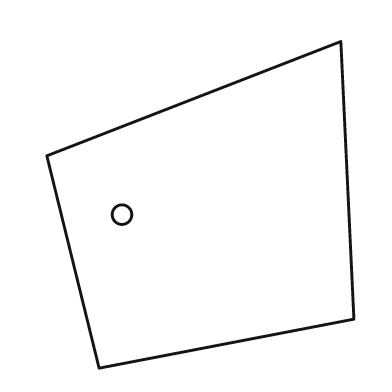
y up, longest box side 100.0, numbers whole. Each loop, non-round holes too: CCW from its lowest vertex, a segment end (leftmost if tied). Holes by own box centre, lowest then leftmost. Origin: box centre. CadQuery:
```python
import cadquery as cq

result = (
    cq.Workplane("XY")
    .moveTo(-31.0, -50.0)
    .lineTo(47.0, -35.0)
    .lineTo(43.0, 50.0)
    .lineTo(-47.0, 15.0)
    .close()
    .moveTo(-24.0, -3.0)
    .circle(3.0)
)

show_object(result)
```